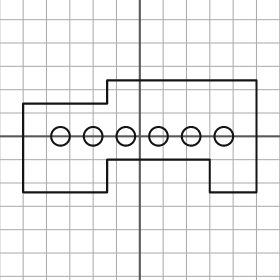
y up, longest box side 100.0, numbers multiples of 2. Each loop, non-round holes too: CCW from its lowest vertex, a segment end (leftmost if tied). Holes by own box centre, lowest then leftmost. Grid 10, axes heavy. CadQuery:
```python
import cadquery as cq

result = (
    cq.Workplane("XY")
    .moveTo(-50.0, -24.0)
    .lineTo(-14.0, -24.0)
    .lineTo(-14.0, -10.0)
    .lineTo(30.0, -10.0)
    .lineTo(30.0, -24.0)
    .lineTo(50.0, -24.0)
    .lineTo(50.0, 24.0)
    .lineTo(-14.0, 24.0)
    .lineTo(-14.0, 14.0)
    .lineTo(-50.0, 14.0)
    .close()
    .moveTo(-34.0, 0.0)
    .circle(4.0)
    .moveTo(-20.0, 0.0)
    .circle(4.0)
    .moveTo(-6.0, 0.0)
    .circle(4.0)
    .moveTo(8.0, 0.0)
    .circle(4.0)
    .moveTo(22.0, 0.0)
    .circle(4.0)
    .moveTo(36.0, 0.0)
    .circle(4.0)
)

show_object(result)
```